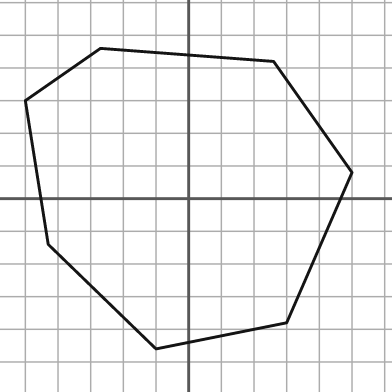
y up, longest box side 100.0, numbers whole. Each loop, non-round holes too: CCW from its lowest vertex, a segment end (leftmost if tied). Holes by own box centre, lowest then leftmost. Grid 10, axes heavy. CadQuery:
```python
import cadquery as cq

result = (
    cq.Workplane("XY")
    .moveTo(-10.0, -46.0)
    .lineTo(30.0, -38.0)
    .lineTo(50.0, 8.0)
    .lineTo(26.0, 42.0)
    .lineTo(-27.0, 46.0)
    .lineTo(-50.0, 30.0)
    .lineTo(-43.0, -14.0)
    .close()
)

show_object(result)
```